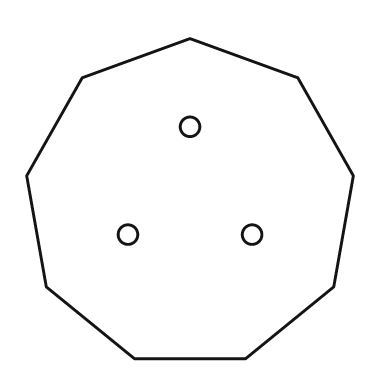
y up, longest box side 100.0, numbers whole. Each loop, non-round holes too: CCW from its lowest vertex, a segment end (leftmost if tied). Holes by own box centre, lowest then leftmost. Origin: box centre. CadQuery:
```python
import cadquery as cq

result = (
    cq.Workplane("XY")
    .moveTo(-17.0, -49.0)
    .lineTo(17.0, -49.0)
    .lineTo(44.0, -27.0)
    .lineTo(50.0, 7.0)
    .lineTo(33.0, 37.0)
    .lineTo(0.0, 49.0)
    .lineTo(-33.0, 37.0)
    .lineTo(-50.0, 7.0)
    .lineTo(-44.0, -27.0)
    .close()
    .moveTo(-19.0, -11.0)
    .circle(3.0)
    .moveTo(19.0, -11.0)
    .circle(3.0)
    .moveTo(0.0, 22.0)
    .circle(3.0)
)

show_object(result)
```